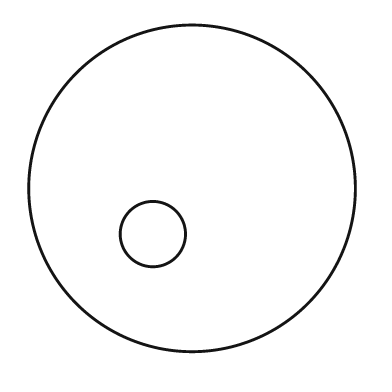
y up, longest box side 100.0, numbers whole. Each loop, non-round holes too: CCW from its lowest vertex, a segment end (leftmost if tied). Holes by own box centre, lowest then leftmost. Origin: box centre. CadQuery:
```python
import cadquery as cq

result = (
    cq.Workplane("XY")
    .moveTo(0.0, 0.0)
    .circle(50.0)
    .moveTo(-12.0, -14.0)
    .circle(10.0)
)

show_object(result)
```